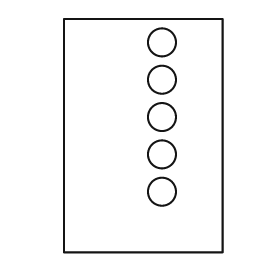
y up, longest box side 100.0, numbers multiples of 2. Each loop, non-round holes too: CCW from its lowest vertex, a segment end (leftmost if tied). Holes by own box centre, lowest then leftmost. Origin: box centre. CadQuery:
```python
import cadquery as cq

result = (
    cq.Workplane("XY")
    .moveTo(-34.0, -50.0)
    .lineTo(34.0, -50.0)
    .lineTo(34.0, 50.0)
    .lineTo(-34.0, 50.0)
    .close()
    .moveTo(8.0, -24.0)
    .circle(6.0)
    .moveTo(8.0, -8.0)
    .circle(6.0)
    .moveTo(8.0, 8.0)
    .circle(6.0)
    .moveTo(8.0, 24.0)
    .circle(6.0)
    .moveTo(8.0, 40.0)
    .circle(6.0)
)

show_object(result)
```